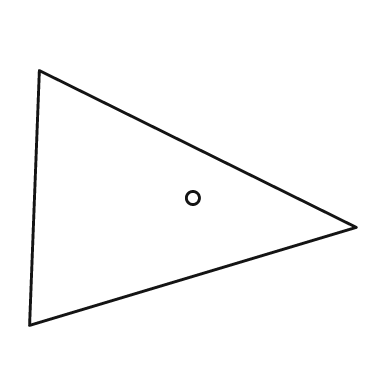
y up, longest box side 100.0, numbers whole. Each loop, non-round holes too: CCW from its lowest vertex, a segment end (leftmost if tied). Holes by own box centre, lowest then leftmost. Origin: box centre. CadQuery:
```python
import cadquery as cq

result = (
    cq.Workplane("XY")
    .moveTo(-50.0, -39.0)
    .lineTo(50.0, -9.0)
    .lineTo(-47.0, 39.0)
    .close()
    .moveTo(0.0, 0.0)
    .circle(2.0)
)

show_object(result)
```